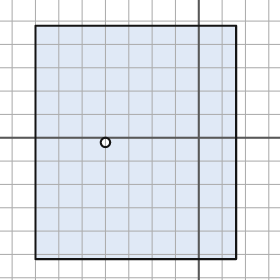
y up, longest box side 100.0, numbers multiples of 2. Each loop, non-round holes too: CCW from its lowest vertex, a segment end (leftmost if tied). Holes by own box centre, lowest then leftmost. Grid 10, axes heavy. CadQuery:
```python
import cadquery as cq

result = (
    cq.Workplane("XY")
    .moveTo(-70.0, -52.0)
    .lineTo(16.0, -52.0)
    .lineTo(16.0, 48.0)
    .lineTo(-70.0, 48.0)
    .close()
    .moveTo(-40.0, -2.0)
    .circle(2.0)
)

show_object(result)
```